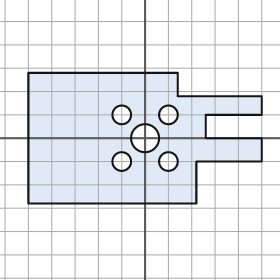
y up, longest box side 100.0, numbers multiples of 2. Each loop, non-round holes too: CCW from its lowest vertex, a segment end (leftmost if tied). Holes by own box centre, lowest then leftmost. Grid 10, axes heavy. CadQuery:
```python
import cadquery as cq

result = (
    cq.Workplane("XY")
    .moveTo(-50.0, -28.0)
    .lineTo(22.0, -28.0)
    .lineTo(22.0, -10.0)
    .lineTo(50.0, -10.0)
    .lineTo(50.0, 0.0)
    .lineTo(26.0, 0.0)
    .lineTo(26.0, 10.0)
    .lineTo(50.0, 10.0)
    .lineTo(50.0, 18.0)
    .lineTo(14.0, 18.0)
    .lineTo(14.0, 28.0)
    .lineTo(-50.0, 28.0)
    .close()
    .moveTo(-10.0, -10.0)
    .circle(4.0)
    .moveTo(10.0, -10.0)
    .circle(4.0)
    .moveTo(0.0, 0.0)
    .circle(6.0)
    .moveTo(-10.0, 10.0)
    .circle(4.0)
    .moveTo(10.0, 10.0)
    .circle(4.0)
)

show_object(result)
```